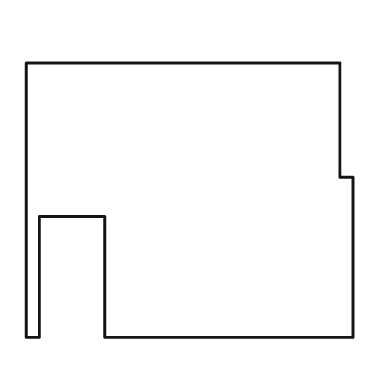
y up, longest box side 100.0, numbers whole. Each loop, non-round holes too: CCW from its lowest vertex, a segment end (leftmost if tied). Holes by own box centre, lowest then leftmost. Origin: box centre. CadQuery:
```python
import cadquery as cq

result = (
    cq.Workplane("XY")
    .moveTo(-50.0, -42.0)
    .lineTo(-46.0, -42.0)
    .lineTo(-46.0, -5.0)
    .lineTo(-26.0, -5.0)
    .lineTo(-26.0, -42.0)
    .lineTo(50.0, -42.0)
    .lineTo(50.0, 7.0)
    .lineTo(46.0, 7.0)
    .lineTo(46.0, 42.0)
    .lineTo(-50.0, 42.0)
    .close()
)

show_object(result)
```